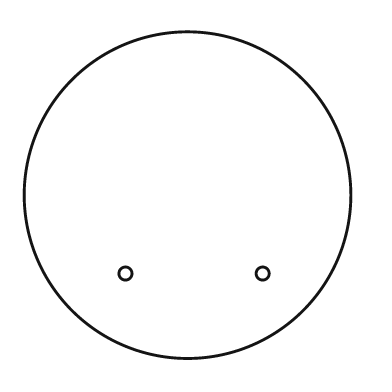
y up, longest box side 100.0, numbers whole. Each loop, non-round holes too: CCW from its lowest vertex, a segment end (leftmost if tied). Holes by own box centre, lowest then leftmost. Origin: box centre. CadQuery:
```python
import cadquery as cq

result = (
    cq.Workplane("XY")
    .moveTo(0.0, 0.0)
    .circle(50.0)
    .moveTo(-19.0, -24.0)
    .circle(2.0)
    .moveTo(23.0, -24.0)
    .circle(2.0)
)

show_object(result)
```